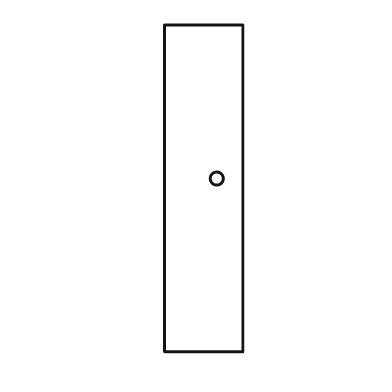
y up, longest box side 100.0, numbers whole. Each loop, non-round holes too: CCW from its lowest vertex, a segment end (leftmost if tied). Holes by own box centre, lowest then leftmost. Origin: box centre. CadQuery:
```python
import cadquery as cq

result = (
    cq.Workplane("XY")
    .moveTo(-12.0, -50.0)
    .lineTo(12.0, -50.0)
    .lineTo(12.0, 50.0)
    .lineTo(-12.0, 50.0)
    .close()
    .moveTo(4.0, 3.0)
    .circle(2.0)
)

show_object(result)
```